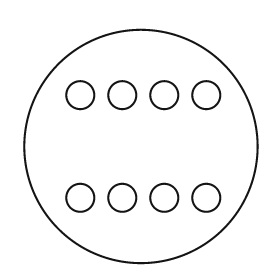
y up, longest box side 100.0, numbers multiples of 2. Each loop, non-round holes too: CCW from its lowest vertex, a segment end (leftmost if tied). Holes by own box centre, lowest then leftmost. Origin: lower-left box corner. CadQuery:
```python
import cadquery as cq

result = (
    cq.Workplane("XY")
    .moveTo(50.0, 50.0)
    .circle(50.0)
    .moveTo(24.0, 28.0)
    .circle(6.0)
    .moveTo(42.0, 28.0)
    .circle(6.0)
    .moveTo(60.0, 28.0)
    .circle(6.0)
    .moveTo(78.0, 28.0)
    .circle(6.0)
    .moveTo(24.0, 72.0)
    .circle(6.0)
    .moveTo(42.0, 72.0)
    .circle(6.0)
    .moveTo(60.0, 72.0)
    .circle(6.0)
    .moveTo(78.0, 72.0)
    .circle(6.0)
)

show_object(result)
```